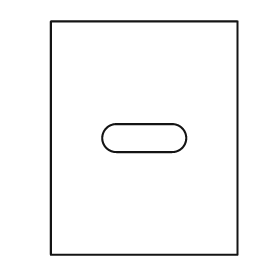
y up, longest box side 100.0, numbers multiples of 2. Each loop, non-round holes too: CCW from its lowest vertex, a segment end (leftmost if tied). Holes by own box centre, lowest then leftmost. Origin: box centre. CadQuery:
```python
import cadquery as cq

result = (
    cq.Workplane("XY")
    .moveTo(-40.0, -50.0)
    .lineTo(40.0, -50.0)
    .lineTo(40.0, 50.0)
    .lineTo(-40.0, 50.0)
    .close()
    .moveTo(-12.0, -6.0)
    .lineTo(12.0, -6.0)
    .threePointArc((18.0, 0.0), (12.0, 6.0))
    .lineTo(-12.0, 6.0)
    .threePointArc((-18.0, 0.0), (-12.0, -6.0))
    .close()
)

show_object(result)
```